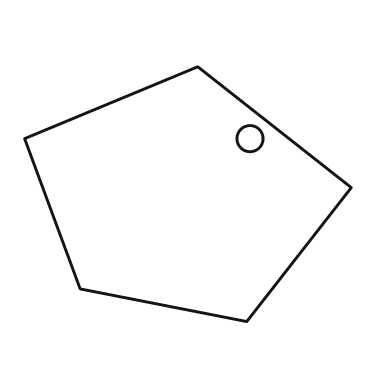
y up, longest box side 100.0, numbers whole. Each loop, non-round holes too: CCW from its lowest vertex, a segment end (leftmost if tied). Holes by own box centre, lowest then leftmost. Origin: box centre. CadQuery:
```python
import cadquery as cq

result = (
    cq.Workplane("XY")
    .moveTo(18.0, -39.0)
    .lineTo(50.0, 2.0)
    .lineTo(3.0, 39.0)
    .lineTo(-50.0, 17.0)
    .lineTo(-33.0, -29.0)
    .close()
    .moveTo(19.0, 17.0)
    .circle(4.0)
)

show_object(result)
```